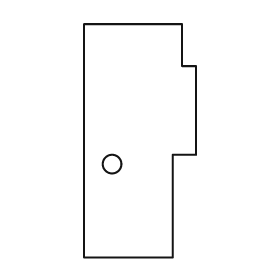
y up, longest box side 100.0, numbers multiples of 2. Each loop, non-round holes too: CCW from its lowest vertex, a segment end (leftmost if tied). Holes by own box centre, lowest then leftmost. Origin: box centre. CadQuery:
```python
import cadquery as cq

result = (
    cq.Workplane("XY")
    .moveTo(-24.0, -50.0)
    .lineTo(14.0, -50.0)
    .lineTo(14.0, -6.0)
    .lineTo(24.0, -6.0)
    .lineTo(24.0, 32.0)
    .lineTo(18.0, 32.0)
    .lineTo(18.0, 50.0)
    .lineTo(-24.0, 50.0)
    .close()
    .moveTo(-12.0, -10.0)
    .circle(4.0)
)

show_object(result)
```